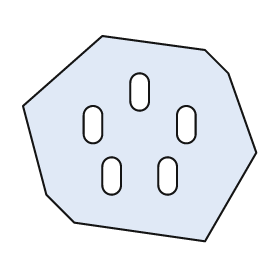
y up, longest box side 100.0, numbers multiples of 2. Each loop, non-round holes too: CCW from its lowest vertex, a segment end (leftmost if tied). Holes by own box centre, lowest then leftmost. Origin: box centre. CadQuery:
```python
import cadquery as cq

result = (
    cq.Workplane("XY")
    .moveTo(28.0, -44.0)
    .lineTo(50.0, -6.0)
    .lineTo(38.0, 28.0)
    .lineTo(28.0, 38.0)
    .lineTo(-16.0, 44.0)
    .lineTo(-50.0, 14.0)
    .lineTo(-40.0, -24.0)
    .lineTo(-28.0, -36.0)
    .close()
    .moveTo(-16.0, -20.0)
    .threePointArc((-12.0, -24.0), (-8.0, -20.0))
    .lineTo(-8.0, -12.0)
    .threePointArc((-12.0, -8.0), (-16.0, -12.0))
    .close()
    .moveTo(8.0, -20.0)
    .threePointArc((12.0, -24.0), (16.0, -20.0))
    .lineTo(16.0, -12.0)
    .threePointArc((12.0, -8.0), (8.0, -12.0))
    .close()
    .moveTo(-24.0, 2.0)
    .threePointArc((-20.0, -2.0), (-16.0, 2.0))
    .lineTo(-16.0, 10.0)
    .threePointArc((-20.0, 14.0), (-24.0, 10.0))
    .close()
    .moveTo(16.0, 2.0)
    .threePointArc((20.0, -2.0), (24.0, 2.0))
    .lineTo(24.0, 10.0)
    .threePointArc((20.0, 14.0), (16.0, 10.0))
    .close()
    .moveTo(-4.0, 16.0)
    .threePointArc((0.0, 12.0), (4.0, 16.0))
    .lineTo(4.0, 24.0)
    .threePointArc((0.0, 28.0), (-4.0, 24.0))
    .close()
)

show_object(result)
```